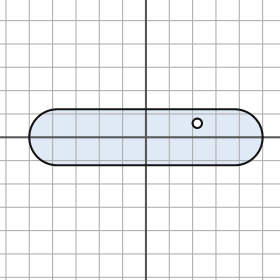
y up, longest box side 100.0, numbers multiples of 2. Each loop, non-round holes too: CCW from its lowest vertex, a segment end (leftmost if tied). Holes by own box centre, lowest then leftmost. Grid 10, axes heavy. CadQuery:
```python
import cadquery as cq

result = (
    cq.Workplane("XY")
    .moveTo(-38.0, -12.0)
    .lineTo(38.0, -12.0)
    .threePointArc((50.0, 0.0), (38.0, 12.0))
    .lineTo(-38.0, 12.0)
    .threePointArc((-50.0, 0.0), (-38.0, -12.0))
    .close()
    .moveTo(22.0, 6.0)
    .circle(2.0)
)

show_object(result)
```